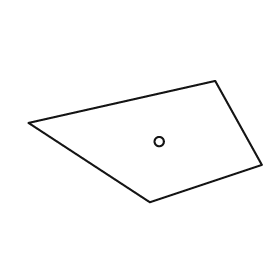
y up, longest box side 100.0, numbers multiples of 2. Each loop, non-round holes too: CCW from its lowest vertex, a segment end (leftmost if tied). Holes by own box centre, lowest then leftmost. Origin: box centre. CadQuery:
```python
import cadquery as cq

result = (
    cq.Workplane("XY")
    .moveTo(2.0, -26.0)
    .lineTo(50.0, -10.0)
    .lineTo(30.0, 26.0)
    .lineTo(-50.0, 8.0)
    .close()
    .moveTo(6.0, 0.0)
    .circle(2.0)
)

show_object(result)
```